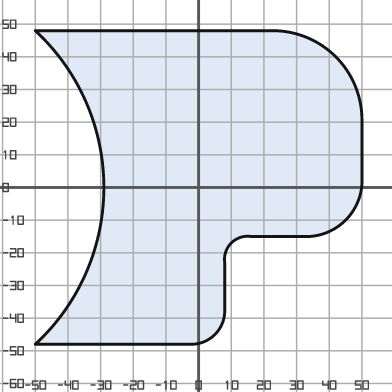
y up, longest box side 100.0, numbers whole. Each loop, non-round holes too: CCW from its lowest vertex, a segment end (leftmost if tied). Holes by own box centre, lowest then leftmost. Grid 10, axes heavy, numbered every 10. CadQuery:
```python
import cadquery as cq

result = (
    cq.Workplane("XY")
    .moveTo(-50.0, -48.0)
    .lineTo(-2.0, -48.0)
    .threePointArc((5.0, -45.0), (8.0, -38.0))
    .lineTo(8.0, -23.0)
    .threePointArc((10.0, -17.0), (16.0, -15.0))
    .lineTo(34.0, -15.0)
    .threePointArc((45.0, -10.0), (50.0, 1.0))
    .lineTo(50.0, 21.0)
    .threePointArc((42.0, 40.0), (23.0, 48.0))
    .lineTo(-50.0, 48.0)
    .threePointArc((-29.0, 0.0), (-50.0, -48.0))
    .close()
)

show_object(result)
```